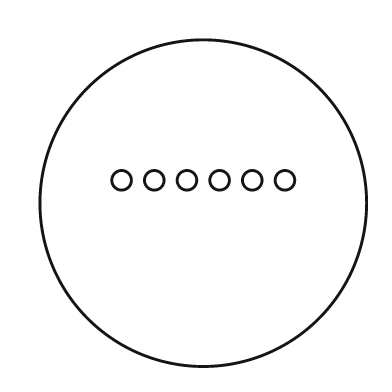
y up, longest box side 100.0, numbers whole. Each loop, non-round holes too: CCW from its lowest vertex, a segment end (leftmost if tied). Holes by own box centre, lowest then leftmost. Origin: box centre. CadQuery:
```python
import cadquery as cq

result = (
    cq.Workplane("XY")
    .moveTo(0.0, 0.0)
    .circle(50.0)
    .moveTo(-25.0, 7.0)
    .circle(3.0)
    .moveTo(-15.0, 7.0)
    .circle(3.0)
    .moveTo(-5.0, 7.0)
    .circle(3.0)
    .moveTo(5.0, 7.0)
    .circle(3.0)
    .moveTo(15.0, 7.0)
    .circle(3.0)
    .moveTo(25.0, 7.0)
    .circle(3.0)
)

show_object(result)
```